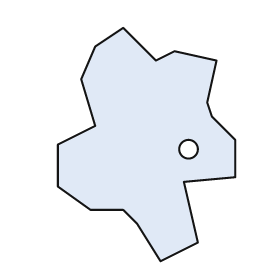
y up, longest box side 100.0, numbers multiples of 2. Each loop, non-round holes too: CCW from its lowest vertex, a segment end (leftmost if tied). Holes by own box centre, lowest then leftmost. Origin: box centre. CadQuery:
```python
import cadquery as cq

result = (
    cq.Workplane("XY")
    .moveTo(6.0, -50.0)
    .lineTo(22.0, -42.0)
    .lineTo(16.0, -16.0)
    .lineTo(38.0, -14.0)
    .lineTo(38.0, 2.0)
    .lineTo(28.0, 12.0)
    .lineTo(26.0, 18.0)
    .lineTo(30.0, 36.0)
    .lineTo(12.0, 40.0)
    .lineTo(4.0, 36.0)
    .lineTo(-10.0, 50.0)
    .lineTo(-22.0, 42.0)
    .lineTo(-28.0, 28.0)
    .lineTo(-22.0, 8.0)
    .lineTo(-38.0, 0.0)
    .lineTo(-38.0, -18.0)
    .lineTo(-24.0, -28.0)
    .lineTo(-10.0, -28.0)
    .lineTo(-4.0, -34.0)
    .close()
    .moveTo(18.0, -2.0)
    .circle(4.0)
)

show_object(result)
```